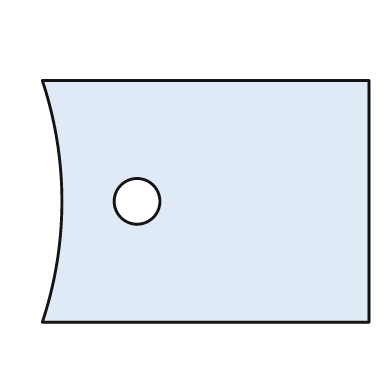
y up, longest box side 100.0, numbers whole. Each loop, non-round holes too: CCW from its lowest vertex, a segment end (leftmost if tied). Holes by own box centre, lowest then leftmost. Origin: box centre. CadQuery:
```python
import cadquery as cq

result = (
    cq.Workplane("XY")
    .moveTo(-50.0, -37.0)
    .lineTo(50.0, -37.0)
    .lineTo(50.0, 37.0)
    .lineTo(-50.0, 37.0)
    .threePointArc((-44.0, 0.0), (-50.0, -37.0))
    .close()
    .moveTo(-21.0, 0.0)
    .circle(7.0)
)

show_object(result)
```